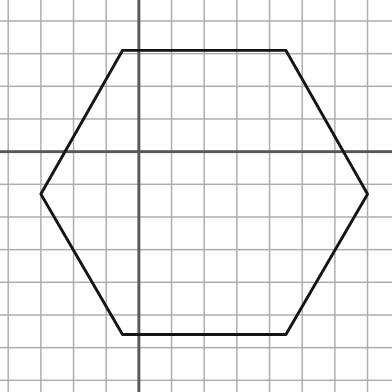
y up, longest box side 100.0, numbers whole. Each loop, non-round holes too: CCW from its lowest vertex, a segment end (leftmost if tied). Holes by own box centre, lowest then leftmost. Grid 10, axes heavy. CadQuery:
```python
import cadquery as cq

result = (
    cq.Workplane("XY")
    .moveTo(-5.0, -56.0)
    .lineTo(45.0, -56.0)
    .lineTo(70.0, -13.0)
    .lineTo(45.0, 31.0)
    .lineTo(-5.0, 31.0)
    .lineTo(-30.0, -13.0)
    .close()
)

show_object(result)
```